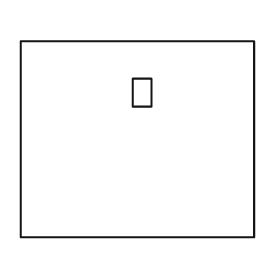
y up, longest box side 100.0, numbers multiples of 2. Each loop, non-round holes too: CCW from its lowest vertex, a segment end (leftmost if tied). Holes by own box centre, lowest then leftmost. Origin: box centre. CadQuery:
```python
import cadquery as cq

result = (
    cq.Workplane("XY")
    .moveTo(-50.0, -42.0)
    .lineTo(50.0, -42.0)
    .lineTo(50.0, 42.0)
    .lineTo(-50.0, 42.0)
    .close()
    .moveTo(-2.0, 14.0)
    .lineTo(6.0, 14.0)
    .lineTo(6.0, 26.0)
    .lineTo(-2.0, 26.0)
    .close()
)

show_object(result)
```